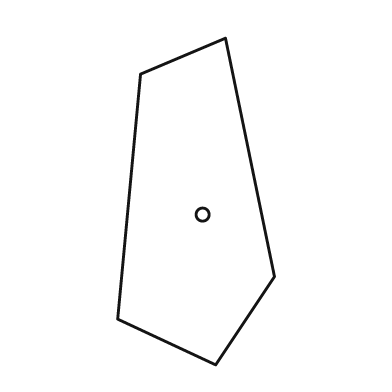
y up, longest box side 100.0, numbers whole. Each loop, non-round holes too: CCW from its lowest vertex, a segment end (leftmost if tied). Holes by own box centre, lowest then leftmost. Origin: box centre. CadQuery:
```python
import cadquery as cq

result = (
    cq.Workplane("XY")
    .moveTo(6.0, -50.0)
    .lineTo(24.0, -23.0)
    .lineTo(9.0, 50.0)
    .lineTo(-17.0, 39.0)
    .lineTo(-24.0, -36.0)
    .close()
    .moveTo(2.0, -4.0)
    .circle(2.0)
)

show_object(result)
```